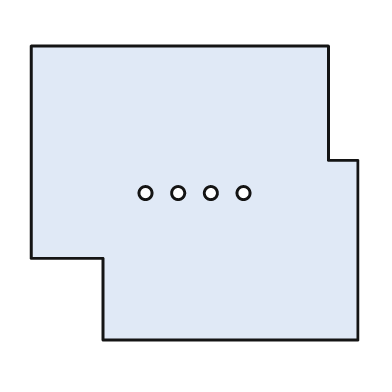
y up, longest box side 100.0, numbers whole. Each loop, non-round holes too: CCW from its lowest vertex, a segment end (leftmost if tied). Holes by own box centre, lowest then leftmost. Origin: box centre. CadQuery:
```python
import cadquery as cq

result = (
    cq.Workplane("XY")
    .moveTo(-28.0, -45.0)
    .lineTo(50.0, -45.0)
    .lineTo(50.0, 10.0)
    .lineTo(41.0, 10.0)
    .lineTo(41.0, 45.0)
    .lineTo(-50.0, 45.0)
    .lineTo(-50.0, -20.0)
    .lineTo(-28.0, -20.0)
    .close()
    .moveTo(-15.0, 0.0)
    .circle(2.0)
    .moveTo(-5.0, 0.0)
    .circle(2.0)
    .moveTo(5.0, 0.0)
    .circle(2.0)
    .moveTo(15.0, 0.0)
    .circle(2.0)
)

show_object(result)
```